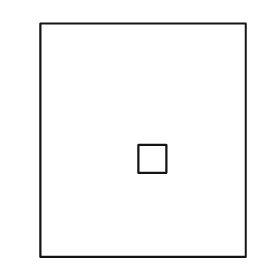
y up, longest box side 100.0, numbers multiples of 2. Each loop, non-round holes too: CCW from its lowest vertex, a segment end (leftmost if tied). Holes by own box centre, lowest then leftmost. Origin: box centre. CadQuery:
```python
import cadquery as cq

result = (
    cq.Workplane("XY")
    .moveTo(-44.0, -50.0)
    .lineTo(44.0, -50.0)
    .lineTo(44.0, 50.0)
    .lineTo(-44.0, 50.0)
    .close()
    .moveTo(-2.0, -14.0)
    .lineTo(10.0, -14.0)
    .lineTo(10.0, -2.0)
    .lineTo(-2.0, -2.0)
    .close()
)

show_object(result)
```